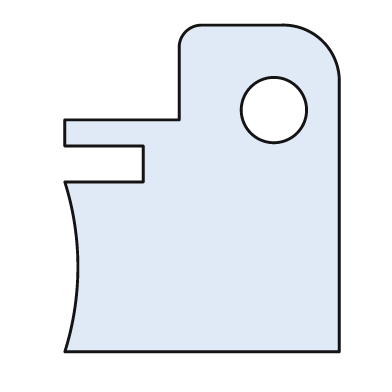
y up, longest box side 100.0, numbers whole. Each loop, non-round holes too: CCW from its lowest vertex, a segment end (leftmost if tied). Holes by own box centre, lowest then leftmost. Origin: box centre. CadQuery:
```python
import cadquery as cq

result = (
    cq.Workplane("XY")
    .moveTo(-42.0, -50.0)
    .lineTo(42.0, -50.0)
    .lineTo(42.0, 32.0)
    .threePointArc((37.0, 45.0), (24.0, 50.0))
    .lineTo(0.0, 50.0)
    .threePointArc((-5.0, 48.0), (-7.0, 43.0))
    .lineTo(-7.0, 21.0)
    .lineTo(-42.0, 21.0)
    .lineTo(-42.0, 13.0)
    .lineTo(-18.0, 13.0)
    .lineTo(-18.0, 2.0)
    .lineTo(-42.0, 2.0)
    .threePointArc((-38.0, -24.0), (-42.0, -50.0))
    .close()
    .moveTo(22.0, 24.0)
    .circle(10.0)
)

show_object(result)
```